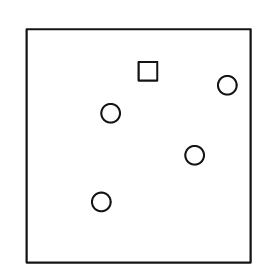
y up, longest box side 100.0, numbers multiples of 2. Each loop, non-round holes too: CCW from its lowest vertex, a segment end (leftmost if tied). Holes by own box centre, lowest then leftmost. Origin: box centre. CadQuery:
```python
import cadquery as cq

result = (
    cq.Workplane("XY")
    .moveTo(-48.0, -50.0)
    .lineTo(48.0, -50.0)
    .lineTo(48.0, 50.0)
    .lineTo(-48.0, 50.0)
    .close()
    .moveTo(-16.0, -24.0)
    .circle(4.0)
    .moveTo(24.0, -4.0)
    .circle(4.0)
    .moveTo(-12.0, 14.0)
    .circle(4.0)
    .moveTo(38.0, 26.0)
    .circle(4.0)
    .moveTo(0.0, 28.0)
    .lineTo(8.0, 28.0)
    .lineTo(8.0, 36.0)
    .lineTo(0.0, 36.0)
    .close()
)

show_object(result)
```